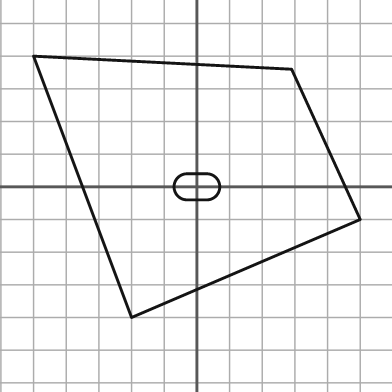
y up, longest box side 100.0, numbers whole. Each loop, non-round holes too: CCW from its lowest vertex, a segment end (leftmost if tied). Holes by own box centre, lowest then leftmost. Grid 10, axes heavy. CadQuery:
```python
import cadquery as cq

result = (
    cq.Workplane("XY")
    .moveTo(-20.0, -40.0)
    .lineTo(50.0, -10.0)
    .lineTo(29.0, 36.0)
    .lineTo(-50.0, 40.0)
    .close()
    .moveTo(-3.0, -4.0)
    .lineTo(3.0, -4.0)
    .threePointArc((7.0, 0.0), (3.0, 4.0))
    .lineTo(-3.0, 4.0)
    .threePointArc((-7.0, 0.0), (-3.0, -4.0))
    .close()
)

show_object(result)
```